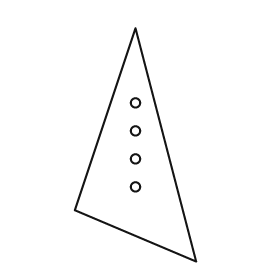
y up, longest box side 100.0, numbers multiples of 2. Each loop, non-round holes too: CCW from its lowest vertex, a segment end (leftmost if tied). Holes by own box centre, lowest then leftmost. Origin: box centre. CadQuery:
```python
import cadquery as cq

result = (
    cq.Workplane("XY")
    .moveTo(26.0, -50.0)
    .lineTo(0.0, 50.0)
    .lineTo(-26.0, -28.0)
    .close()
    .moveTo(0.0, -18.0)
    .circle(2.0)
    .moveTo(0.0, -6.0)
    .circle(2.0)
    .moveTo(0.0, 6.0)
    .circle(2.0)
    .moveTo(0.0, 18.0)
    .circle(2.0)
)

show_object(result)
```